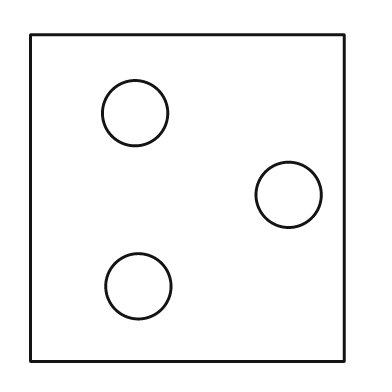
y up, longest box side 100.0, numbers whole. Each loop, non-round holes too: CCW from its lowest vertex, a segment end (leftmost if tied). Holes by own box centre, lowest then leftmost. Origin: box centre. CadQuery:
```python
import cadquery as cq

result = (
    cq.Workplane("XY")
    .moveTo(-48.0, -50.0)
    .lineTo(48.0, -50.0)
    .lineTo(48.0, 50.0)
    .lineTo(-48.0, 50.0)
    .close()
    .moveTo(-15.0, -27.0)
    .circle(10.0)
    .moveTo(31.0, 1.0)
    .circle(10.0)
    .moveTo(-16.0, 26.0)
    .circle(10.0)
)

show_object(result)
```